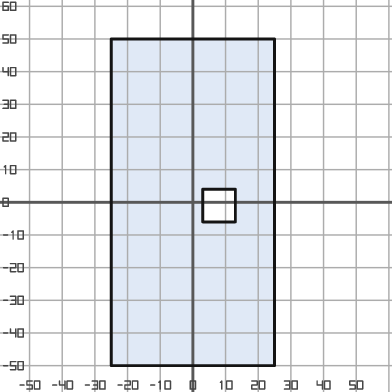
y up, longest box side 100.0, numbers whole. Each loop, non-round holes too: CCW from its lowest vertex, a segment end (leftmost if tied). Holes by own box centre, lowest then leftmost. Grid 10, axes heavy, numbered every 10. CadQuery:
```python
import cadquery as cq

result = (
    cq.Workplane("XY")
    .moveTo(-25.0, -50.0)
    .lineTo(25.0, -50.0)
    .lineTo(25.0, 50.0)
    .lineTo(-25.0, 50.0)
    .close()
    .moveTo(3.0, -6.0)
    .lineTo(13.0, -6.0)
    .lineTo(13.0, 4.0)
    .lineTo(3.0, 4.0)
    .close()
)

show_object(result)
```